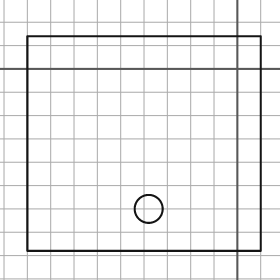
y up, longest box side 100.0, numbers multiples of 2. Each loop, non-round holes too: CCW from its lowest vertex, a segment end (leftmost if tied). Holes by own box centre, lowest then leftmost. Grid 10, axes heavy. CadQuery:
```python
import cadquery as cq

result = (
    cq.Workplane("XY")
    .moveTo(-90.0, -78.0)
    .lineTo(10.0, -78.0)
    .lineTo(10.0, 14.0)
    .lineTo(-90.0, 14.0)
    .close()
    .moveTo(-38.0, -60.0)
    .circle(6.0)
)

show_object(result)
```